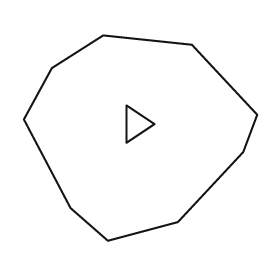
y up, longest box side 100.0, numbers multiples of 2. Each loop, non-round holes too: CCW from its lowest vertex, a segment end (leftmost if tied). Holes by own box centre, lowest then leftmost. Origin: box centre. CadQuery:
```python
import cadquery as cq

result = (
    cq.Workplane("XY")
    .moveTo(-14.0, -44.0)
    .lineTo(16.0, -36.0)
    .lineTo(44.0, -6.0)
    .lineTo(50.0, 10.0)
    .lineTo(22.0, 40.0)
    .lineTo(-16.0, 44.0)
    .lineTo(-38.0, 30.0)
    .lineTo(-50.0, 8.0)
    .lineTo(-30.0, -30.0)
    .close()
    .moveTo(-6.0, -2.0)
    .lineTo(6.0, 6.0)
    .lineTo(-6.0, 14.0)
    .close()
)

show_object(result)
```